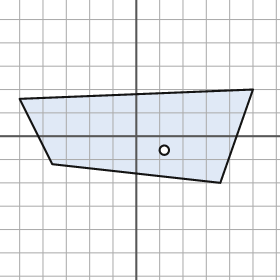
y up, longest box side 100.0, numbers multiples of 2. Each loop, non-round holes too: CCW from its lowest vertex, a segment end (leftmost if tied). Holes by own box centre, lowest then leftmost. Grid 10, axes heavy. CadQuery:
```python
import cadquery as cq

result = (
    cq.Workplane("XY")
    .moveTo(36.0, -20.0)
    .lineTo(50.0, 20.0)
    .lineTo(-50.0, 16.0)
    .lineTo(-36.0, -12.0)
    .close()
    .moveTo(12.0, -6.0)
    .circle(2.0)
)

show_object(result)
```